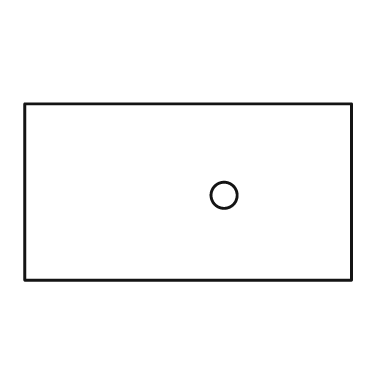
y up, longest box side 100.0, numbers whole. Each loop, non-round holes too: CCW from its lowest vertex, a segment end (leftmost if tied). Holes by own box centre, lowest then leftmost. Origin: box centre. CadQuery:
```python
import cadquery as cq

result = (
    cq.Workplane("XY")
    .moveTo(-50.0, -27.0)
    .lineTo(50.0, -27.0)
    .lineTo(50.0, 27.0)
    .lineTo(-50.0, 27.0)
    .close()
    .moveTo(11.0, -1.0)
    .circle(4.0)
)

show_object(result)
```